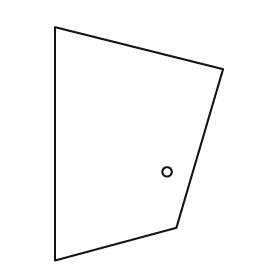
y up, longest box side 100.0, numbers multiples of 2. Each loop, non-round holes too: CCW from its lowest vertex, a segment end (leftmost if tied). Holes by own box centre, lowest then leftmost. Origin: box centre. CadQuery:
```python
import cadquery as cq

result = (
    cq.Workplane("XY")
    .moveTo(-36.0, -50.0)
    .lineTo(16.0, -36.0)
    .lineTo(36.0, 32.0)
    .lineTo(-36.0, 50.0)
    .close()
    .moveTo(12.0, -12.0)
    .circle(2.0)
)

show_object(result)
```